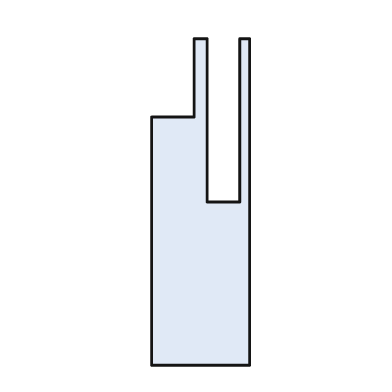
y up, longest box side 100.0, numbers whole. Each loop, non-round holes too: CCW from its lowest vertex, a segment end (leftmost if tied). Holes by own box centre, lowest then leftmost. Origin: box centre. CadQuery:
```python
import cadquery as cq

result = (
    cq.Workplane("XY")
    .moveTo(-15.0, -50.0)
    .lineTo(15.0, -50.0)
    .lineTo(15.0, 50.0)
    .lineTo(12.0, 50.0)
    .lineTo(12.0, 0.0)
    .lineTo(2.0, 0.0)
    .lineTo(2.0, 50.0)
    .lineTo(-2.0, 50.0)
    .lineTo(-2.0, 26.0)
    .lineTo(-15.0, 26.0)
    .close()
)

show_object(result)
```